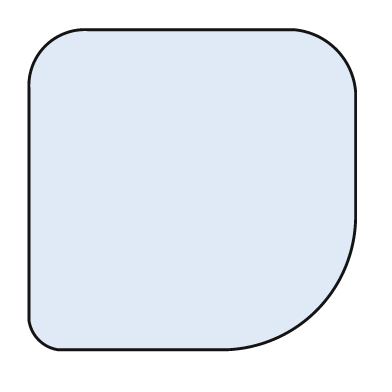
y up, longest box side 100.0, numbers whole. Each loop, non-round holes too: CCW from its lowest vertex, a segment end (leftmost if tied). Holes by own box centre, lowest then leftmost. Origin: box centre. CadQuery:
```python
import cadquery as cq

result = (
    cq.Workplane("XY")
    .moveTo(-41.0, -49.0)
    .lineTo(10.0, -49.0)
    .threePointArc((38.0, -37.0), (50.0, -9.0))
    .lineTo(50.0, 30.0)
    .threePointArc((44.0, 43.0), (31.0, 49.0))
    .lineTo(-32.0, 49.0)
    .threePointArc((-45.0, 44.0), (-50.0, 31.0))
    .lineTo(-50.0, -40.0)
    .threePointArc((-47.0, -46.0), (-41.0, -49.0))
    .close()
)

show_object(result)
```